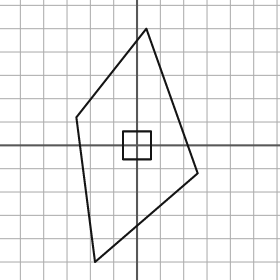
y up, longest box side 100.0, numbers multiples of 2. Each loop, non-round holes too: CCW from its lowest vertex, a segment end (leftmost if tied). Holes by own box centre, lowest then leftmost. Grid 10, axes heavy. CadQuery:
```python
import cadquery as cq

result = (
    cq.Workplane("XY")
    .moveTo(-18.0, -50.0)
    .lineTo(26.0, -12.0)
    .lineTo(4.0, 50.0)
    .lineTo(-26.0, 12.0)
    .close()
    .moveTo(-6.0, -6.0)
    .lineTo(6.0, -6.0)
    .lineTo(6.0, 6.0)
    .lineTo(-6.0, 6.0)
    .close()
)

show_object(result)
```